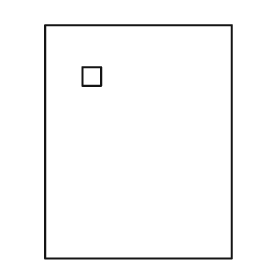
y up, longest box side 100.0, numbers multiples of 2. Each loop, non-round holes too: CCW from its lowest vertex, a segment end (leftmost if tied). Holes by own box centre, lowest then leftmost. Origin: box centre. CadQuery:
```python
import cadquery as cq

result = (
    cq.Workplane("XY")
    .moveTo(-40.0, -50.0)
    .lineTo(40.0, -50.0)
    .lineTo(40.0, 50.0)
    .lineTo(-40.0, 50.0)
    .close()
    .moveTo(-24.0, 24.0)
    .lineTo(-16.0, 24.0)
    .lineTo(-16.0, 32.0)
    .lineTo(-24.0, 32.0)
    .close()
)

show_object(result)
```